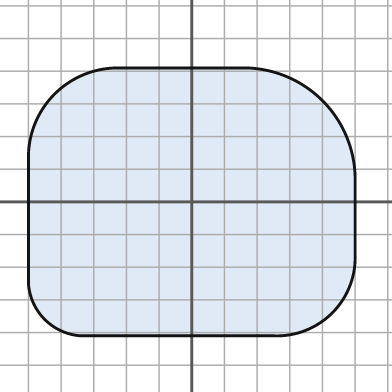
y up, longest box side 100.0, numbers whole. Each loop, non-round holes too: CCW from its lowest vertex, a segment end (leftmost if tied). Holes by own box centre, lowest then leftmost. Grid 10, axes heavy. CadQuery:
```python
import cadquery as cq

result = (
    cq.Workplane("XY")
    .moveTo(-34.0, -41.0)
    .lineTo(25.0, -41.0)
    .threePointArc((43.0, -34.0), (50.0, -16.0))
    .lineTo(50.0, 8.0)
    .threePointArc((40.0, 31.0), (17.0, 41.0))
    .lineTo(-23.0, 41.0)
    .threePointArc((-42.0, 33.0), (-50.0, 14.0))
    .lineTo(-50.0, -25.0)
    .threePointArc((-45.0, -36.0), (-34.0, -41.0))
    .close()
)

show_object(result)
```